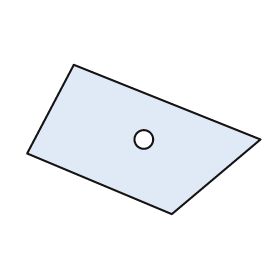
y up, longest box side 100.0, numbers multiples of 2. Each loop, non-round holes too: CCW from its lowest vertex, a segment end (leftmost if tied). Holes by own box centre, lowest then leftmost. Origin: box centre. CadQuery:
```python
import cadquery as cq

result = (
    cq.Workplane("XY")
    .moveTo(12.0, -32.0)
    .lineTo(50.0, 0.0)
    .lineTo(-30.0, 32.0)
    .lineTo(-50.0, -6.0)
    .close()
    .moveTo(0.0, 0.0)
    .circle(4.0)
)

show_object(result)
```